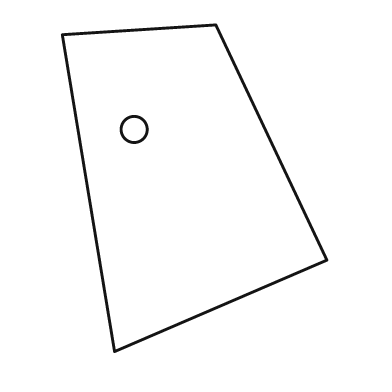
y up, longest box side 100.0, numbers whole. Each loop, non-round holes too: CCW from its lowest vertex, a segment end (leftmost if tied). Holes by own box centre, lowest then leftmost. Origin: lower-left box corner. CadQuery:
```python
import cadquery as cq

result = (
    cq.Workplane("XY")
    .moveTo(16.0, 0.0)
    .lineTo(81.0, 28.0)
    .lineTo(47.0, 100.0)
    .lineTo(0.0, 97.0)
    .close()
    .moveTo(22.0, 68.0)
    .circle(4.0)
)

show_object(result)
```